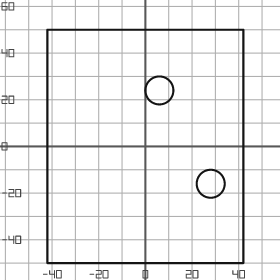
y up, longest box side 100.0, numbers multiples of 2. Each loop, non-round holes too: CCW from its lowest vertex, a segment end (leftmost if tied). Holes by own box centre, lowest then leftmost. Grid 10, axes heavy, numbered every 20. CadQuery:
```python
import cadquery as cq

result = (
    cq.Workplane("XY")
    .moveTo(-42.0, -50.0)
    .lineTo(42.0, -50.0)
    .lineTo(42.0, 50.0)
    .lineTo(-42.0, 50.0)
    .close()
    .moveTo(28.0, -16.0)
    .circle(6.0)
    .moveTo(6.0, 24.0)
    .circle(6.0)
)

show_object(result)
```